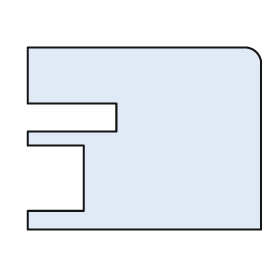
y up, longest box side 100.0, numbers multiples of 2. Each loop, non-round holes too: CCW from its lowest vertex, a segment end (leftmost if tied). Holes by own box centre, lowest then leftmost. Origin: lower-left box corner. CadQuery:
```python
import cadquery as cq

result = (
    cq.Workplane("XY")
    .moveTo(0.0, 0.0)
    .lineTo(100.0, 0.0)
    .lineTo(100.0, 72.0)
    .threePointArc((98.0, 76.0), (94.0, 78.0))
    .lineTo(0.0, 78.0)
    .lineTo(0.0, 54.0)
    .lineTo(38.0, 54.0)
    .lineTo(38.0, 42.0)
    .lineTo(0.0, 42.0)
    .lineTo(0.0, 36.0)
    .lineTo(24.0, 36.0)
    .lineTo(24.0, 8.0)
    .lineTo(0.0, 8.0)
    .close()
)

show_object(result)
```